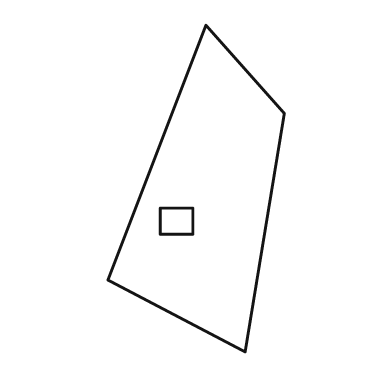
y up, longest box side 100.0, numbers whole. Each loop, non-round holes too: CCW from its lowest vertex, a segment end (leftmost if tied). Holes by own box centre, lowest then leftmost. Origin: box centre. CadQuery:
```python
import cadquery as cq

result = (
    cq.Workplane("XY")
    .moveTo(15.0, -50.0)
    .lineTo(27.0, 23.0)
    .lineTo(3.0, 50.0)
    .lineTo(-27.0, -28.0)
    .close()
    .moveTo(-11.0, -14.0)
    .lineTo(-1.0, -14.0)
    .lineTo(-1.0, -6.0)
    .lineTo(-11.0, -6.0)
    .close()
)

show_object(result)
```